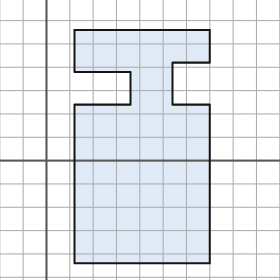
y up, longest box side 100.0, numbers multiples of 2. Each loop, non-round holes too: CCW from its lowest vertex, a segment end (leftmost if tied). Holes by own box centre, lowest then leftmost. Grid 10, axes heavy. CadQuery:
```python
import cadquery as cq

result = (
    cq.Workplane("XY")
    .moveTo(12.0, -44.0)
    .lineTo(70.0, -44.0)
    .lineTo(70.0, 24.0)
    .lineTo(54.0, 24.0)
    .lineTo(54.0, 42.0)
    .lineTo(70.0, 42.0)
    .lineTo(70.0, 56.0)
    .lineTo(12.0, 56.0)
    .lineTo(12.0, 38.0)
    .lineTo(36.0, 38.0)
    .lineTo(36.0, 24.0)
    .lineTo(12.0, 24.0)
    .close()
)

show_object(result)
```